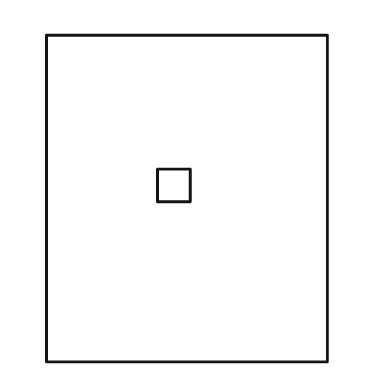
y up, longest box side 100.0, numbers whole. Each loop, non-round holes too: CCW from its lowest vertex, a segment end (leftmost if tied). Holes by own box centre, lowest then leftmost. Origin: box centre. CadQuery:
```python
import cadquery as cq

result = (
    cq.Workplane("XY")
    .moveTo(-43.0, -50.0)
    .lineTo(43.0, -50.0)
    .lineTo(43.0, 50.0)
    .lineTo(-43.0, 50.0)
    .close()
    .moveTo(-9.0, -1.0)
    .lineTo(1.0, -1.0)
    .lineTo(1.0, 9.0)
    .lineTo(-9.0, 9.0)
    .close()
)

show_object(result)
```